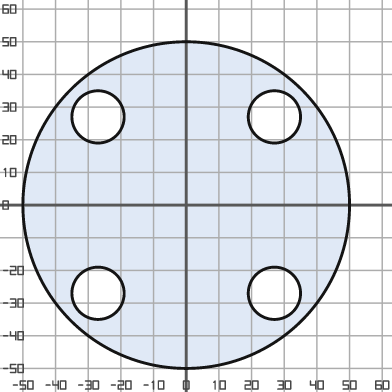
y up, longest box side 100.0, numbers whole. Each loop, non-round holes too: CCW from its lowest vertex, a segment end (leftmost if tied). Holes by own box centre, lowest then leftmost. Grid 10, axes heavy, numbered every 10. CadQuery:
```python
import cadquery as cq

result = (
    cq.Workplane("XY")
    .moveTo(0.0, 0.0)
    .circle(50.0)
    .moveTo(-27.0, -27.0)
    .circle(8.0)
    .moveTo(27.0, -27.0)
    .circle(8.0)
    .moveTo(-27.0, 27.0)
    .circle(8.0)
    .moveTo(27.0, 27.0)
    .circle(8.0)
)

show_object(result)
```